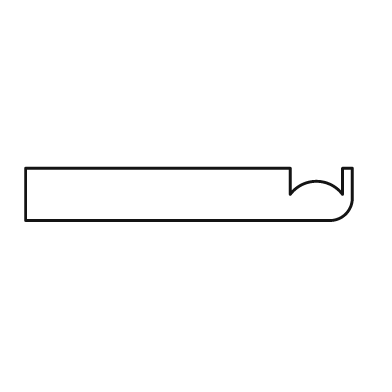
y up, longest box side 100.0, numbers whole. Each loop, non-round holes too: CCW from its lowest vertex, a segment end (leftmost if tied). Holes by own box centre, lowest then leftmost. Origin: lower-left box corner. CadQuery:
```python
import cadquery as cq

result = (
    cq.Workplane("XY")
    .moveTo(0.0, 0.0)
    .lineTo(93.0, 0.0)
    .threePointArc((98.0, 2.0), (100.0, 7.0))
    .lineTo(100.0, 16.0)
    .lineTo(97.0, 16.0)
    .lineTo(97.0, 8.0)
    .threePointArc((89.0, 12.0), (81.0, 8.0))
    .lineTo(81.0, 16.0)
    .lineTo(0.0, 16.0)
    .close()
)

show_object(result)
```